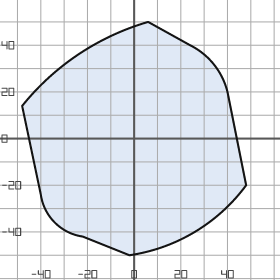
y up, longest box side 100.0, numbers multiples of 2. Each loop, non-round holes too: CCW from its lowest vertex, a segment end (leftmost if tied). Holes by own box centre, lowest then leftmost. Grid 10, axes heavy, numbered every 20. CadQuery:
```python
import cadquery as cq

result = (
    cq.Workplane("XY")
    .moveTo(-2.0, -50.0)
    .threePointArc((26.0, -40.0), (48.0, -20.0))
    .lineTo(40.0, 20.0)
    .threePointArc((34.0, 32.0), (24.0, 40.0))
    .lineTo(6.0, 50.0)
    .threePointArc((-24.0, 36.0), (-48.0, 14.0))
    .lineTo(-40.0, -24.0)
    .threePointArc((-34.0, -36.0), (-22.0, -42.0))
    .close()
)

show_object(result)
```